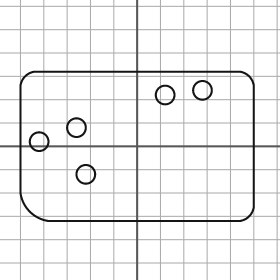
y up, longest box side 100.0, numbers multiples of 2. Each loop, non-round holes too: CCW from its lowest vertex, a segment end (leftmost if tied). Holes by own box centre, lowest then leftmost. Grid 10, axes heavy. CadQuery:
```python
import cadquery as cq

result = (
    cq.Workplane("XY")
    .moveTo(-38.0, -32.0)
    .lineTo(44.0, -32.0)
    .threePointArc((48.0, -30.0), (50.0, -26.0))
    .lineTo(50.0, 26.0)
    .threePointArc((48.0, 30.0), (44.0, 32.0))
    .lineTo(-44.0, 32.0)
    .threePointArc((-48.0, 30.0), (-50.0, 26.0))
    .lineTo(-50.0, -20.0)
    .threePointArc((-46.0, -28.0), (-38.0, -32.0))
    .close()
    .moveTo(-22.0, -12.0)
    .circle(4.0)
    .moveTo(-42.0, 2.0)
    .circle(4.0)
    .moveTo(-26.0, 8.0)
    .circle(4.0)
    .moveTo(12.0, 22.0)
    .circle(4.0)
    .moveTo(28.0, 24.0)
    .circle(4.0)
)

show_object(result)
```